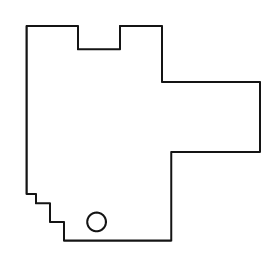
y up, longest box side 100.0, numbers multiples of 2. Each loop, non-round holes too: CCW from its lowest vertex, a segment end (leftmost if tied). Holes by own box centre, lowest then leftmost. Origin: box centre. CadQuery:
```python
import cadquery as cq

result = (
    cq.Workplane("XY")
    .moveTo(-34.0, -46.0)
    .lineTo(12.0, -46.0)
    .lineTo(12.0, -8.0)
    .lineTo(50.0, -8.0)
    .lineTo(50.0, 22.0)
    .lineTo(8.0, 22.0)
    .lineTo(8.0, 46.0)
    .lineTo(-10.0, 46.0)
    .lineTo(-10.0, 36.0)
    .lineTo(-28.0, 36.0)
    .lineTo(-28.0, 46.0)
    .lineTo(-50.0, 46.0)
    .lineTo(-50.0, -26.0)
    .lineTo(-46.0, -26.0)
    .lineTo(-46.0, -30.0)
    .lineTo(-40.0, -30.0)
    .lineTo(-40.0, -38.0)
    .lineTo(-34.0, -38.0)
    .close()
    .moveTo(-20.0, -38.0)
    .circle(4.0)
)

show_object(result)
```